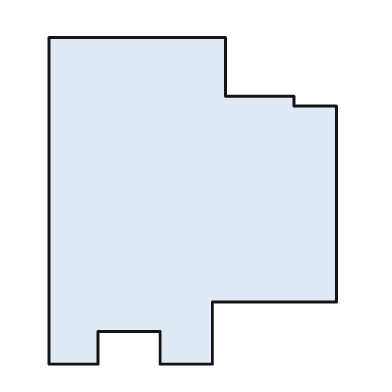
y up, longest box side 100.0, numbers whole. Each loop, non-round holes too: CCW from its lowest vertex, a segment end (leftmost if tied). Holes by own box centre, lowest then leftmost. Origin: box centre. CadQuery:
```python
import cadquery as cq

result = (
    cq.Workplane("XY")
    .moveTo(-44.0, -50.0)
    .lineTo(-29.0, -50.0)
    .lineTo(-29.0, -40.0)
    .lineTo(-10.0, -40.0)
    .lineTo(-10.0, -50.0)
    .lineTo(6.0, -50.0)
    .lineTo(6.0, -31.0)
    .lineTo(44.0, -31.0)
    .lineTo(44.0, 29.0)
    .lineTo(31.0, 29.0)
    .lineTo(31.0, 32.0)
    .lineTo(10.0, 32.0)
    .lineTo(10.0, 50.0)
    .lineTo(-44.0, 50.0)
    .close()
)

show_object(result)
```